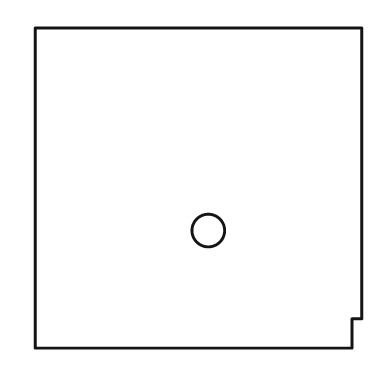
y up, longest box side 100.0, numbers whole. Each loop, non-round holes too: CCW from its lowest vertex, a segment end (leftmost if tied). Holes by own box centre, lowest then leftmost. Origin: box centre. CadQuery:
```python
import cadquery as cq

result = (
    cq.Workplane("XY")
    .moveTo(-50.0, -49.0)
    .lineTo(47.0, -49.0)
    .lineTo(47.0, -40.0)
    .lineTo(50.0, -40.0)
    .lineTo(50.0, 49.0)
    .lineTo(-50.0, 49.0)
    .close()
    .moveTo(3.0, -13.0)
    .circle(5.0)
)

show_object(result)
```